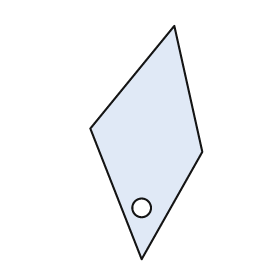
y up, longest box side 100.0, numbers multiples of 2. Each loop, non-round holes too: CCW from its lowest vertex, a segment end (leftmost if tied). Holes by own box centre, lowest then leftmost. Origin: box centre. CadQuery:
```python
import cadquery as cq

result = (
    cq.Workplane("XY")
    .moveTo(-2.0, -50.0)
    .lineTo(24.0, -4.0)
    .lineTo(12.0, 50.0)
    .lineTo(-24.0, 6.0)
    .close()
    .moveTo(-2.0, -28.0)
    .circle(4.0)
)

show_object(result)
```